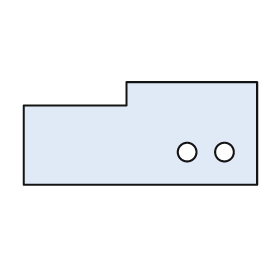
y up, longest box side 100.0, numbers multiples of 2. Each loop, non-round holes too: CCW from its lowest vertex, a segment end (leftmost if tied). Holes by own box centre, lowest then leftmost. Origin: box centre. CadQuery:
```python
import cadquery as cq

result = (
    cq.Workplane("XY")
    .moveTo(-50.0, -22.0)
    .lineTo(50.0, -22.0)
    .lineTo(50.0, 22.0)
    .lineTo(-6.0, 22.0)
    .lineTo(-6.0, 12.0)
    .lineTo(-50.0, 12.0)
    .close()
    .moveTo(20.0, -8.0)
    .circle(4.0)
    .moveTo(36.0, -8.0)
    .circle(4.0)
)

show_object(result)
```